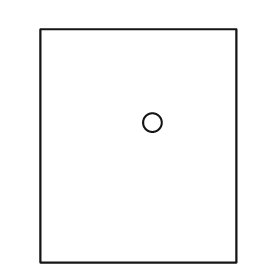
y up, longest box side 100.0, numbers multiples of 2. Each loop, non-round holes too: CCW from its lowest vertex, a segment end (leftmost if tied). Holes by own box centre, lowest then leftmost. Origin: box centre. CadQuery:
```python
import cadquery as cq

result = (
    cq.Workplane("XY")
    .moveTo(-42.0, -50.0)
    .lineTo(42.0, -50.0)
    .lineTo(42.0, 50.0)
    .lineTo(-42.0, 50.0)
    .close()
    .moveTo(6.0, 10.0)
    .circle(4.0)
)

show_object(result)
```